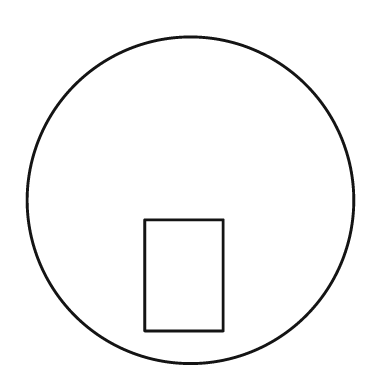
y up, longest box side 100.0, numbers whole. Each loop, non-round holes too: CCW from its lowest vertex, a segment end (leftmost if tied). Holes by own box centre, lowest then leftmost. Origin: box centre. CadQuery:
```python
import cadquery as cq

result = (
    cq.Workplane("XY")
    .moveTo(0.0, 0.0)
    .circle(50.0)
    .moveTo(-14.0, -40.0)
    .lineTo(10.0, -40.0)
    .lineTo(10.0, -6.0)
    .lineTo(-14.0, -6.0)
    .close()
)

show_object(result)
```